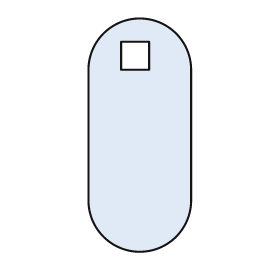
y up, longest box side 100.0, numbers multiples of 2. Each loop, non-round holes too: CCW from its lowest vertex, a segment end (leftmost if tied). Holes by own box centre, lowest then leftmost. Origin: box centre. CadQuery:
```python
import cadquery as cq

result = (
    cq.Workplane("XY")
    .moveTo(-22.0, -28.0)
    .threePointArc((0.0, -50.0), (22.0, -28.0))
    .lineTo(22.0, 28.0)
    .threePointArc((0.0, 50.0), (-22.0, 28.0))
    .close()
    .moveTo(-8.0, 28.0)
    .lineTo(4.0, 28.0)
    .lineTo(4.0, 40.0)
    .lineTo(-8.0, 40.0)
    .close()
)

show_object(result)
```